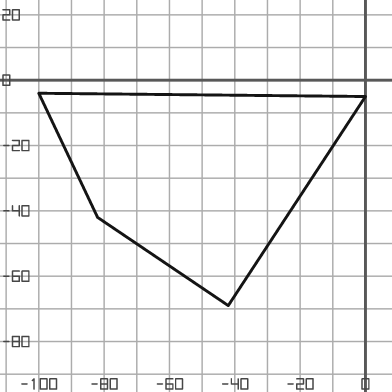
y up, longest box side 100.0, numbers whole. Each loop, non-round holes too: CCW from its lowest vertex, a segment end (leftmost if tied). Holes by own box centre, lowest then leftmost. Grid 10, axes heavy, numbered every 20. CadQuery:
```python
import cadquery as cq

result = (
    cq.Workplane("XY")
    .moveTo(-42.0, -69.0)
    .lineTo(0.0, -5.0)
    .lineTo(-100.0, -4.0)
    .lineTo(-82.0, -42.0)
    .close()
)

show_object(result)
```